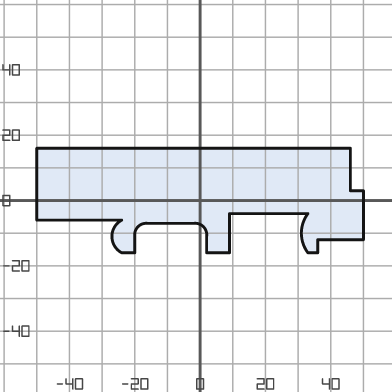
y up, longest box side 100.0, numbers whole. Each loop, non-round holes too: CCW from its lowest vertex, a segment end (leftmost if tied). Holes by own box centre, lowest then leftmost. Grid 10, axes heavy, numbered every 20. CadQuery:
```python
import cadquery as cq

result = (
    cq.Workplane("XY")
    .moveTo(-24.0, -16.0)
    .lineTo(-20.0, -16.0)
    .lineTo(-20.0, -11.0)
    .threePointArc((-19.0, -8.0), (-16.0, -7.0))
    .lineTo(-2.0, -7.0)
    .threePointArc((1.0, -8.0), (2.0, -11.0))
    .lineTo(2.0, -16.0)
    .lineTo(9.0, -16.0)
    .lineTo(9.0, -4.0)
    .lineTo(33.0, -4.0)
    .threePointArc((31.0, -10.0), (33.0, -16.0))
    .lineTo(36.0, -16.0)
    .lineTo(36.0, -12.0)
    .lineTo(50.0, -12.0)
    .lineTo(50.0, 3.0)
    .lineTo(46.0, 3.0)
    .lineTo(46.0, 16.0)
    .lineTo(-50.0, 16.0)
    .lineTo(-50.0, -6.0)
    .lineTo(-24.0, -6.0)
    .threePointArc((-27.0, -11.0), (-24.0, -16.0))
    .close()
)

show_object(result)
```